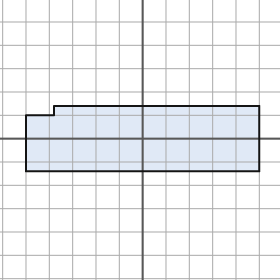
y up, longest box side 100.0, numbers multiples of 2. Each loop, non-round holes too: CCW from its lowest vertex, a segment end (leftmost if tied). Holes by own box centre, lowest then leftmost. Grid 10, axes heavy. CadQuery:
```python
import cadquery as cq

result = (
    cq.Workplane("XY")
    .moveTo(-50.0, -14.0)
    .lineTo(50.0, -14.0)
    .lineTo(50.0, 14.0)
    .lineTo(-38.0, 14.0)
    .lineTo(-38.0, 10.0)
    .lineTo(-50.0, 10.0)
    .close()
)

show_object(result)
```